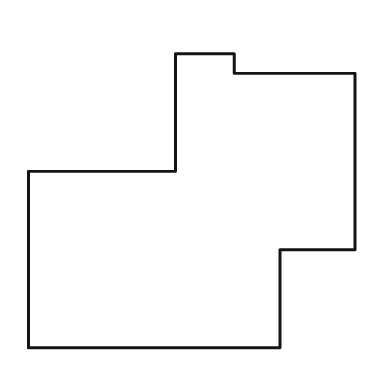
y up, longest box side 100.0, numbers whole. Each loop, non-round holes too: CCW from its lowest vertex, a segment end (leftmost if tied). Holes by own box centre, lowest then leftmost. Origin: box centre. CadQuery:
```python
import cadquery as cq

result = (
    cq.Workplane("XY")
    .moveTo(-50.0, -45.0)
    .lineTo(27.0, -45.0)
    .lineTo(27.0, -15.0)
    .lineTo(50.0, -15.0)
    .lineTo(50.0, 39.0)
    .lineTo(13.0, 39.0)
    .lineTo(13.0, 45.0)
    .lineTo(-5.0, 45.0)
    .lineTo(-5.0, 9.0)
    .lineTo(-50.0, 9.0)
    .close()
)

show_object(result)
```